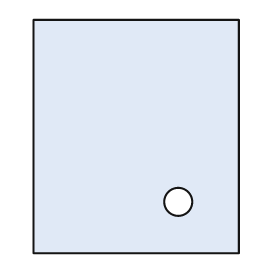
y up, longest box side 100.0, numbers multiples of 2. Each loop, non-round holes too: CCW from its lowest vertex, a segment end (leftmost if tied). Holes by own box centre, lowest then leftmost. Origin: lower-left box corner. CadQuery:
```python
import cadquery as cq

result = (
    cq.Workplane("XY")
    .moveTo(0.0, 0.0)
    .lineTo(88.0, 0.0)
    .lineTo(88.0, 100.0)
    .lineTo(0.0, 100.0)
    .close()
    .moveTo(62.0, 22.0)
    .circle(6.0)
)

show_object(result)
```